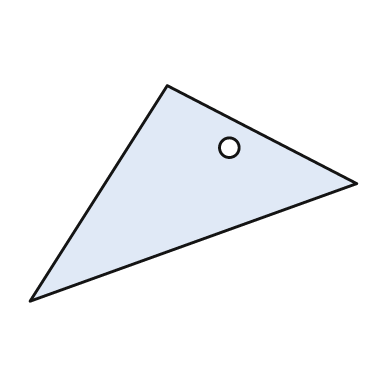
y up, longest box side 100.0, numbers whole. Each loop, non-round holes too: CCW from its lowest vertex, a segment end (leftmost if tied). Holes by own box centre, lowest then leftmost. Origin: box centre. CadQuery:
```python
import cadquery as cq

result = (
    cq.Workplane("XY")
    .moveTo(-50.0, -33.0)
    .lineTo(50.0, 3.0)
    .lineTo(-8.0, 33.0)
    .close()
    .moveTo(11.0, 14.0)
    .circle(3.0)
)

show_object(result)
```